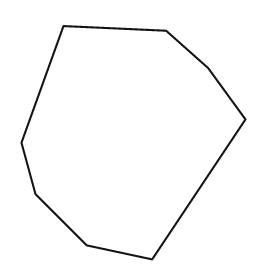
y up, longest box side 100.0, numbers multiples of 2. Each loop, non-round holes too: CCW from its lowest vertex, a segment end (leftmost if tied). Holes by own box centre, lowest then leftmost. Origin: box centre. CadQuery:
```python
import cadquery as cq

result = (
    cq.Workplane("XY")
    .moveTo(8.0, -50.0)
    .lineTo(48.0, 10.0)
    .lineTo(32.0, 32.0)
    .lineTo(14.0, 48.0)
    .lineTo(-30.0, 50.0)
    .lineTo(-48.0, 0.0)
    .lineTo(-42.0, -22.0)
    .lineTo(-20.0, -44.0)
    .close()
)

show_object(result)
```